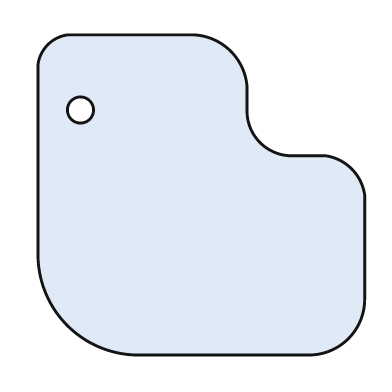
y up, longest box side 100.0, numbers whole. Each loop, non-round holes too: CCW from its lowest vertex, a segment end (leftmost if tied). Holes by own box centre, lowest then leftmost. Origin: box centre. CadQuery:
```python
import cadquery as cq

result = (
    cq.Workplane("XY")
    .moveTo(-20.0, -49.0)
    .lineTo(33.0, -49.0)
    .threePointArc((45.0, -44.0), (50.0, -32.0))
    .lineTo(50.0, 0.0)
    .threePointArc((46.0, 8.0), (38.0, 12.0))
    .lineTo(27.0, 12.0)
    .threePointArc((18.0, 16.0), (14.0, 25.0))
    .lineTo(14.0, 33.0)
    .threePointArc((9.0, 44.0), (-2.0, 49.0))
    .lineTo(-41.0, 49.0)
    .threePointArc((-47.0, 46.0), (-50.0, 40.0))
    .lineTo(-50.0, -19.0)
    .threePointArc((-41.0, -40.0), (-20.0, -49.0))
    .close()
    .moveTo(-37.0, 26.0)
    .circle(4.0)
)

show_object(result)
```